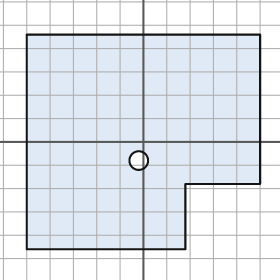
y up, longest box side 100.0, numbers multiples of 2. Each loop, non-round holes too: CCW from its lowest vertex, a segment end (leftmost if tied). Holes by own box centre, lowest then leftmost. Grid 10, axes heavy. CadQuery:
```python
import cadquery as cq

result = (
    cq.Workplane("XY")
    .moveTo(-50.0, -46.0)
    .lineTo(18.0, -46.0)
    .lineTo(18.0, -18.0)
    .lineTo(50.0, -18.0)
    .lineTo(50.0, 46.0)
    .lineTo(-50.0, 46.0)
    .close()
    .moveTo(-2.0, -8.0)
    .circle(4.0)
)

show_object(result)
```